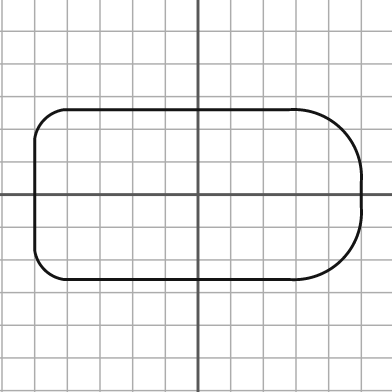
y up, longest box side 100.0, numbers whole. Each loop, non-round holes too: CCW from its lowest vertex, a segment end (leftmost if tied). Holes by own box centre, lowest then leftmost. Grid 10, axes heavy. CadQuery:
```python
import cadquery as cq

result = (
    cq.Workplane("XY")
    .moveTo(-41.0, -26.0)
    .lineTo(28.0, -26.0)
    .threePointArc((44.0, -20.0), (50.0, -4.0))
    .lineTo(50.0, 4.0)
    .threePointArc((44.0, 20.0), (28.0, 26.0))
    .lineTo(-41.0, 26.0)
    .threePointArc((-47.0, 23.0), (-50.0, 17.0))
    .lineTo(-50.0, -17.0)
    .threePointArc((-47.0, -23.0), (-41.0, -26.0))
    .close()
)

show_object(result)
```